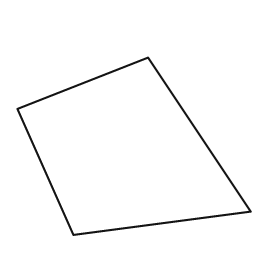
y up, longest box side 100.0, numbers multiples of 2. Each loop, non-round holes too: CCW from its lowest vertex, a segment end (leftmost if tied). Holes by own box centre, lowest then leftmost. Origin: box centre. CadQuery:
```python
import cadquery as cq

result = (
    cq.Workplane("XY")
    .moveTo(-26.0, -38.0)
    .lineTo(50.0, -28.0)
    .lineTo(6.0, 38.0)
    .lineTo(-50.0, 16.0)
    .close()
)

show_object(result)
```